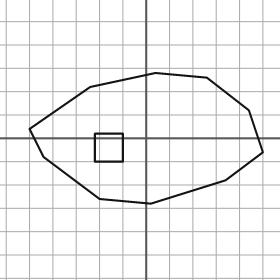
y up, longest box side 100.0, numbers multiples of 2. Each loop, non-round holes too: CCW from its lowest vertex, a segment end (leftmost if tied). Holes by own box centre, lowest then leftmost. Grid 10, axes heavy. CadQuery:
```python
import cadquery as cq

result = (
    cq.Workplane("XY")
    .moveTo(2.0, -28.0)
    .lineTo(34.0, -18.0)
    .lineTo(50.0, -6.0)
    .lineTo(44.0, 12.0)
    .lineTo(26.0, 26.0)
    .lineTo(4.0, 28.0)
    .lineTo(-24.0, 22.0)
    .lineTo(-50.0, 4.0)
    .lineTo(-44.0, -8.0)
    .lineTo(-20.0, -26.0)
    .close()
    .moveTo(-22.0, -10.0)
    .lineTo(-10.0, -10.0)
    .lineTo(-10.0, 2.0)
    .lineTo(-22.0, 2.0)
    .close()
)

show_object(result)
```